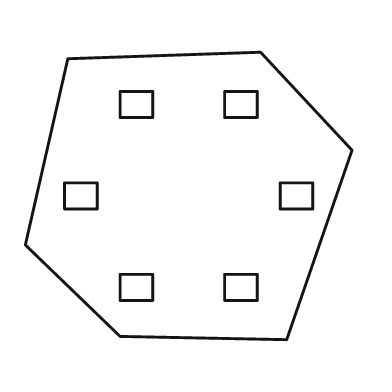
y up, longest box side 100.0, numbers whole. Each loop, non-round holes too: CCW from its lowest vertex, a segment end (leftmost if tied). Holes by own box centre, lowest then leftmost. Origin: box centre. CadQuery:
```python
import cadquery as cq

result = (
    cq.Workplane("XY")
    .moveTo(30.0, -44.0)
    .lineTo(50.0, 14.0)
    .lineTo(22.0, 44.0)
    .lineTo(-37.0, 42.0)
    .lineTo(-50.0, -15.0)
    .lineTo(-21.0, -43.0)
    .close()
    .moveTo(-21.0, -32.0)
    .lineTo(-11.0, -32.0)
    .lineTo(-11.0, -24.0)
    .lineTo(-21.0, -24.0)
    .close()
    .moveTo(11.0, -32.0)
    .lineTo(21.0, -32.0)
    .lineTo(21.0, -24.0)
    .lineTo(11.0, -24.0)
    .close()
    .moveTo(-38.0, -4.0)
    .lineTo(-28.0, -4.0)
    .lineTo(-28.0, 4.0)
    .lineTo(-38.0, 4.0)
    .close()
    .moveTo(28.0, -4.0)
    .lineTo(38.0, -4.0)
    .lineTo(38.0, 4.0)
    .lineTo(28.0, 4.0)
    .close()
    .moveTo(-21.0, 24.0)
    .lineTo(-11.0, 24.0)
    .lineTo(-11.0, 32.0)
    .lineTo(-21.0, 32.0)
    .close()
    .moveTo(11.0, 24.0)
    .lineTo(21.0, 24.0)
    .lineTo(21.0, 32.0)
    .lineTo(11.0, 32.0)
    .close()
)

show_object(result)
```